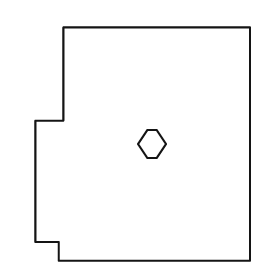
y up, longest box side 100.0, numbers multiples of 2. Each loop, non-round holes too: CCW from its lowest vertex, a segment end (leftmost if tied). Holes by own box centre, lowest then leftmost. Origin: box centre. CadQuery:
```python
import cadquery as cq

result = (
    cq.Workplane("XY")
    .moveTo(-36.0, -50.0)
    .lineTo(46.0, -50.0)
    .lineTo(46.0, 50.0)
    .lineTo(-34.0, 50.0)
    .lineTo(-34.0, 10.0)
    .lineTo(-46.0, 10.0)
    .lineTo(-46.0, -42.0)
    .lineTo(-36.0, -42.0)
    .close()
    .moveTo(2.0, -6.0)
    .lineTo(6.0, -6.0)
    .lineTo(10.0, 0.0)
    .lineTo(6.0, 6.0)
    .lineTo(2.0, 6.0)
    .lineTo(-2.0, 0.0)
    .close()
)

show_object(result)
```